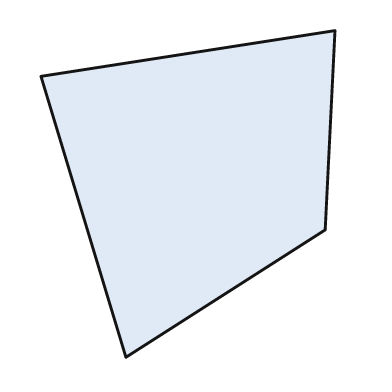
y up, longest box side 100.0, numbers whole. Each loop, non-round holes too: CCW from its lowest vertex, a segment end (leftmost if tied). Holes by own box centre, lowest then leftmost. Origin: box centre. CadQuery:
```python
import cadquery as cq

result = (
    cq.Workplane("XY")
    .moveTo(-19.0, -50.0)
    .lineTo(42.0, -11.0)
    .lineTo(45.0, 50.0)
    .lineTo(-45.0, 36.0)
    .close()
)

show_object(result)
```